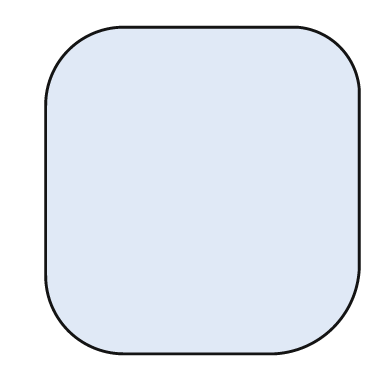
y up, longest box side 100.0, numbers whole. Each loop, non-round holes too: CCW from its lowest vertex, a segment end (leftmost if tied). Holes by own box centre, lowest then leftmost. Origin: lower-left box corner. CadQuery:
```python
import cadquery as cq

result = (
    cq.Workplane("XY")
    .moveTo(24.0, 0.0)
    .lineTo(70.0, 0.0)
    .threePointArc((88.0, 8.0), (96.0, 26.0))
    .lineTo(96.0, 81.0)
    .threePointArc((90.0, 94.0), (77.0, 100.0))
    .lineTo(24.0, 100.0)
    .threePointArc((7.0, 93.0), (0.0, 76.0))
    .lineTo(0.0, 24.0)
    .threePointArc((7.0, 7.0), (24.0, 0.0))
    .close()
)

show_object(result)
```